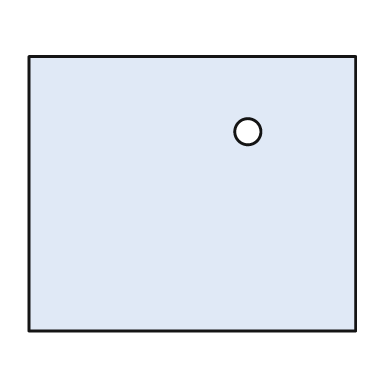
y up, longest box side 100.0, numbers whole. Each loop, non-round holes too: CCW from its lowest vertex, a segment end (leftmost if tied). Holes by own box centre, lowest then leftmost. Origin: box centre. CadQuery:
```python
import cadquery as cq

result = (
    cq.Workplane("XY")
    .moveTo(-50.0, -42.0)
    .lineTo(50.0, -42.0)
    .lineTo(50.0, 42.0)
    .lineTo(-50.0, 42.0)
    .close()
    .moveTo(17.0, 19.0)
    .circle(4.0)
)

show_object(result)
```